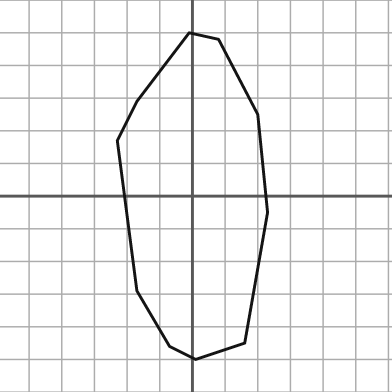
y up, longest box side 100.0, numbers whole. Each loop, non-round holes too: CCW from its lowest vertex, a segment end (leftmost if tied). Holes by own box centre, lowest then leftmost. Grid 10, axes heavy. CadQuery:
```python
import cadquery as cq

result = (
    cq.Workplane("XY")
    .moveTo(1.0, -50.0)
    .lineTo(16.0, -45.0)
    .lineTo(23.0, -5.0)
    .lineTo(20.0, 25.0)
    .lineTo(8.0, 48.0)
    .lineTo(-1.0, 50.0)
    .lineTo(-17.0, 29.0)
    .lineTo(-23.0, 17.0)
    .lineTo(-17.0, -29.0)
    .lineTo(-7.0, -46.0)
    .close()
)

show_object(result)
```